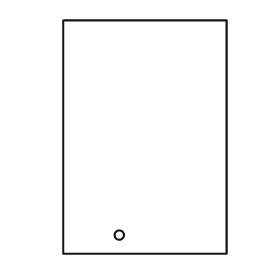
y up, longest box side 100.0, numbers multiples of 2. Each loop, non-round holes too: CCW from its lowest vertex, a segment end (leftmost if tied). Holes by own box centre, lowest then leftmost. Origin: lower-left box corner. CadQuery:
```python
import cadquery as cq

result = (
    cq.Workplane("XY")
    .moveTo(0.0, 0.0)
    .lineTo(70.0, 0.0)
    .lineTo(70.0, 100.0)
    .lineTo(0.0, 100.0)
    .close()
    .moveTo(24.0, 8.0)
    .circle(2.0)
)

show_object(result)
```